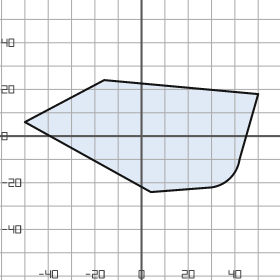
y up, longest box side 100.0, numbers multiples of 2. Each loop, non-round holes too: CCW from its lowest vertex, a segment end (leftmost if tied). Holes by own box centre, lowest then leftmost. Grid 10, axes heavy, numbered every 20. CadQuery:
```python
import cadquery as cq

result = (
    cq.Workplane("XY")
    .moveTo(4.0, -24.0)
    .lineTo(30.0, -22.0)
    .threePointArc((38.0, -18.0), (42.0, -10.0))
    .lineTo(50.0, 18.0)
    .lineTo(-16.0, 24.0)
    .lineTo(-50.0, 6.0)
    .close()
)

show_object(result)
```